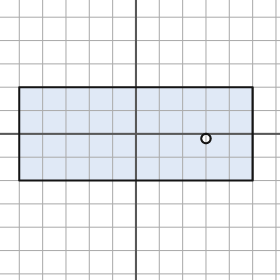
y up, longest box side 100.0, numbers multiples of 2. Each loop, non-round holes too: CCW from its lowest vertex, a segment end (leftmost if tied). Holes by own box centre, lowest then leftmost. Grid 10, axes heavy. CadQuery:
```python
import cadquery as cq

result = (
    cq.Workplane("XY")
    .moveTo(-50.0, -20.0)
    .lineTo(50.0, -20.0)
    .lineTo(50.0, 20.0)
    .lineTo(-50.0, 20.0)
    .close()
    .moveTo(30.0, -2.0)
    .circle(2.0)
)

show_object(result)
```